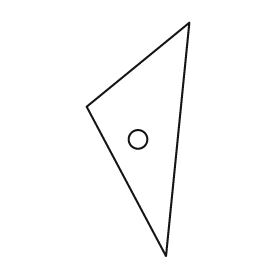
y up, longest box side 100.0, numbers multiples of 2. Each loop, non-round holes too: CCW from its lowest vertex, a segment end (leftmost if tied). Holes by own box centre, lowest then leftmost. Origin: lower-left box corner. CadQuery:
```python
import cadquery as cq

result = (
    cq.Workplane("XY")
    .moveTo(34.0, 0.0)
    .lineTo(44.0, 100.0)
    .lineTo(0.0, 64.0)
    .close()
    .moveTo(22.0, 50.0)
    .circle(4.0)
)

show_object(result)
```